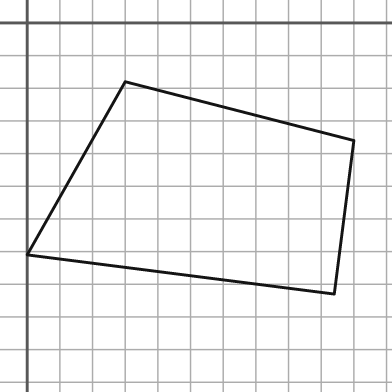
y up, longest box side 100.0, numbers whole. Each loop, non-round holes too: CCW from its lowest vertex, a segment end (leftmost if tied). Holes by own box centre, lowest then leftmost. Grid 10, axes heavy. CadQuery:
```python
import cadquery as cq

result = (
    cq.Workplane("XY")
    .moveTo(94.0, -83.0)
    .lineTo(100.0, -36.0)
    .lineTo(30.0, -18.0)
    .lineTo(0.0, -71.0)
    .close()
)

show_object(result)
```